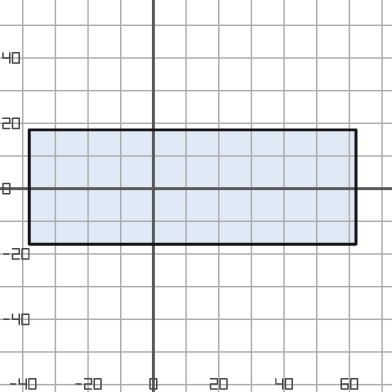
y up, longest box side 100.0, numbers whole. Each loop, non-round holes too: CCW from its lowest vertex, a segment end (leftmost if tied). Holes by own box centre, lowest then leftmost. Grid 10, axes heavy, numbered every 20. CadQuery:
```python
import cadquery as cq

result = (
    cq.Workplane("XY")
    .moveTo(-38.0, -17.0)
    .lineTo(62.0, -17.0)
    .lineTo(62.0, 18.0)
    .lineTo(-38.0, 18.0)
    .close()
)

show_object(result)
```